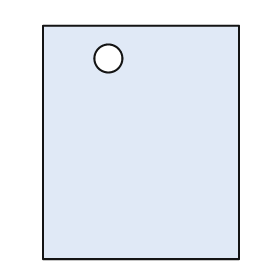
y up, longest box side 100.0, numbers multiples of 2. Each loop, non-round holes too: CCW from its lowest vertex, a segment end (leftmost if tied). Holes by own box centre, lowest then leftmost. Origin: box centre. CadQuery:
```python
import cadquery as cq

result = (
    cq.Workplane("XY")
    .moveTo(-42.0, -50.0)
    .lineTo(42.0, -50.0)
    .lineTo(42.0, 50.0)
    .lineTo(-42.0, 50.0)
    .close()
    .moveTo(-14.0, 36.0)
    .circle(6.0)
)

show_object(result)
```